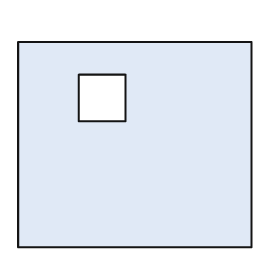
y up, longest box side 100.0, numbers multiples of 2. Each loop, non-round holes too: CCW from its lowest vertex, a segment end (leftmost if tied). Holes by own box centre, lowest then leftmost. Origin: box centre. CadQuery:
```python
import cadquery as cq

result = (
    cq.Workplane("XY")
    .moveTo(-50.0, -44.0)
    .lineTo(50.0, -44.0)
    .lineTo(50.0, 44.0)
    .lineTo(-50.0, 44.0)
    .close()
    .moveTo(-24.0, 10.0)
    .lineTo(-4.0, 10.0)
    .lineTo(-4.0, 30.0)
    .lineTo(-24.0, 30.0)
    .close()
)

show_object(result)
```